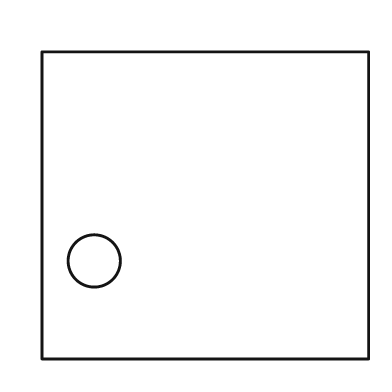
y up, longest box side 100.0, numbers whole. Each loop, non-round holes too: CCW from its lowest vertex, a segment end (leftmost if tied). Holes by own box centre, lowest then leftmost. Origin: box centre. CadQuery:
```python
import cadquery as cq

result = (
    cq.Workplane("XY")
    .moveTo(-50.0, -47.0)
    .lineTo(50.0, -47.0)
    .lineTo(50.0, 47.0)
    .lineTo(-50.0, 47.0)
    .close()
    .moveTo(-34.0, -17.0)
    .circle(8.0)
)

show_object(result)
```